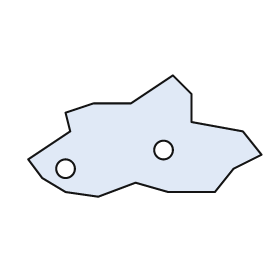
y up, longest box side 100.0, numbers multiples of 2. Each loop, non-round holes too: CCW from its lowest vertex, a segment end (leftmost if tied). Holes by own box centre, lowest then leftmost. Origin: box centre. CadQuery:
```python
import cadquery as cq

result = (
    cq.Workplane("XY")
    .moveTo(-20.0, -26.0)
    .lineTo(-4.0, -20.0)
    .lineTo(10.0, -24.0)
    .lineTo(30.0, -24.0)
    .lineTo(38.0, -14.0)
    .lineTo(50.0, -8.0)
    .lineTo(42.0, 2.0)
    .lineTo(20.0, 6.0)
    .lineTo(20.0, 18.0)
    .lineTo(12.0, 26.0)
    .lineTo(-6.0, 14.0)
    .lineTo(-22.0, 14.0)
    .lineTo(-34.0, 10.0)
    .lineTo(-32.0, 2.0)
    .lineTo(-50.0, -10.0)
    .lineTo(-44.0, -18.0)
    .lineTo(-34.0, -24.0)
    .close()
    .moveTo(-34.0, -14.0)
    .circle(4.0)
    .moveTo(8.0, -6.0)
    .circle(4.0)
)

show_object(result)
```